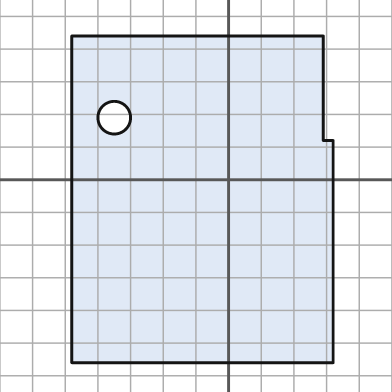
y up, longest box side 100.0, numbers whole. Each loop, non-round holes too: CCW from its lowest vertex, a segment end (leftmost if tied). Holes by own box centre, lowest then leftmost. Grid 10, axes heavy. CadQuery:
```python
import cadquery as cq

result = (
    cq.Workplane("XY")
    .moveTo(-48.0, -56.0)
    .lineTo(32.0, -56.0)
    .lineTo(32.0, 12.0)
    .lineTo(29.0, 12.0)
    .lineTo(29.0, 44.0)
    .lineTo(-48.0, 44.0)
    .close()
    .moveTo(-35.0, 19.0)
    .circle(5.0)
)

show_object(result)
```